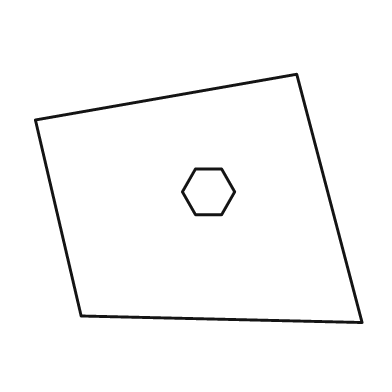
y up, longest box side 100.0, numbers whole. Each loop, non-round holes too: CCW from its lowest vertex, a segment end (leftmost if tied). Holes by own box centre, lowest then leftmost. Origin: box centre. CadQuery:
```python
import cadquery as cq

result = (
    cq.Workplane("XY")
    .moveTo(50.0, -38.0)
    .lineTo(30.0, 38.0)
    .lineTo(-50.0, 24.0)
    .lineTo(-36.0, -36.0)
    .close()
    .moveTo(-1.0, -5.0)
    .lineTo(7.0, -5.0)
    .lineTo(11.0, 2.0)
    .lineTo(7.0, 9.0)
    .lineTo(-1.0, 9.0)
    .lineTo(-5.0, 2.0)
    .close()
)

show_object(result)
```